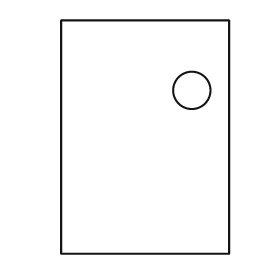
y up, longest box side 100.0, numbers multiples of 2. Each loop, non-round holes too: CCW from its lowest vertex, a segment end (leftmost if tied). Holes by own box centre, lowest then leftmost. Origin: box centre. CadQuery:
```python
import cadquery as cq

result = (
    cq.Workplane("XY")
    .moveTo(-36.0, -50.0)
    .lineTo(36.0, -50.0)
    .lineTo(36.0, 50.0)
    .lineTo(-36.0, 50.0)
    .close()
    .moveTo(20.0, 20.0)
    .circle(8.0)
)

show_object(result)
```